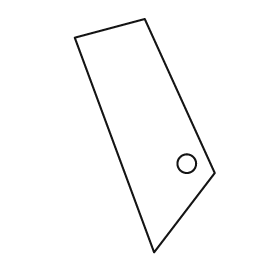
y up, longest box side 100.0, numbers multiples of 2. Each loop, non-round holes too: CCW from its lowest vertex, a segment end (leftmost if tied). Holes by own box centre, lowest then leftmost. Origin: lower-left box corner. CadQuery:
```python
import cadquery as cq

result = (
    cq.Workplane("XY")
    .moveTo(34.0, 0.0)
    .lineTo(60.0, 34.0)
    .lineTo(30.0, 100.0)
    .lineTo(0.0, 92.0)
    .close()
    .moveTo(48.0, 38.0)
    .circle(4.0)
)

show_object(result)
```